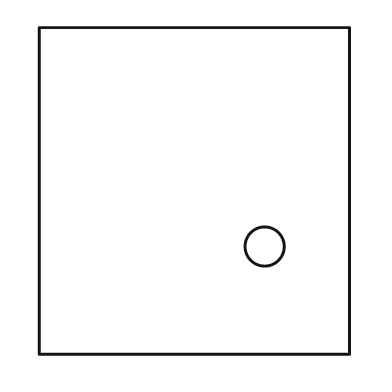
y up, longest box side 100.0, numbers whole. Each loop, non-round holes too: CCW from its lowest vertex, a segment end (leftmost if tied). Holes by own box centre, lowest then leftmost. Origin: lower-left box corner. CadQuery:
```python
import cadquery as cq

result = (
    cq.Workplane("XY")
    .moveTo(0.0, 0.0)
    .lineTo(95.0, 0.0)
    .lineTo(95.0, 100.0)
    .lineTo(0.0, 100.0)
    .close()
    .moveTo(69.0, 33.0)
    .circle(6.0)
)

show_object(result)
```